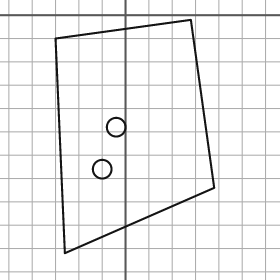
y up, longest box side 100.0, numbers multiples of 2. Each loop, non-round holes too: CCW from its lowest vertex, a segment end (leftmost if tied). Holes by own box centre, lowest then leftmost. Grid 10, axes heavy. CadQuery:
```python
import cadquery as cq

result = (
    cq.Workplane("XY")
    .moveTo(-26.0, -102.0)
    .lineTo(38.0, -74.0)
    .lineTo(28.0, -2.0)
    .lineTo(-30.0, -10.0)
    .close()
    .moveTo(-10.0, -66.0)
    .circle(4.0)
    .moveTo(-4.0, -48.0)
    .circle(4.0)
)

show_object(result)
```